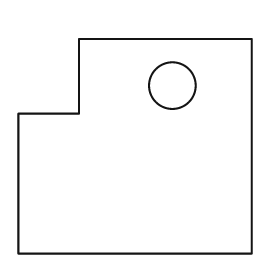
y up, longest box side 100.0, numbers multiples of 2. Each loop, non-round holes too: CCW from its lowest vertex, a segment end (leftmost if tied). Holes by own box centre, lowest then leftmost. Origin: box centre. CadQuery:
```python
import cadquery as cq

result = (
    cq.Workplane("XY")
    .moveTo(-50.0, -46.0)
    .lineTo(50.0, -46.0)
    .lineTo(50.0, 46.0)
    .lineTo(-24.0, 46.0)
    .lineTo(-24.0, 14.0)
    .lineTo(-50.0, 14.0)
    .close()
    .moveTo(16.0, 26.0)
    .circle(10.0)
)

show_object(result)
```